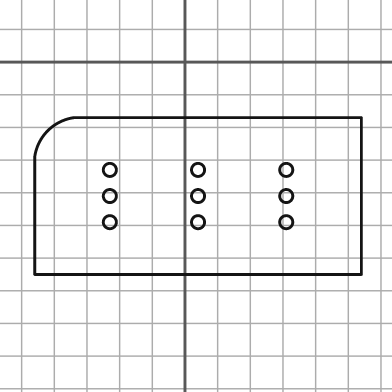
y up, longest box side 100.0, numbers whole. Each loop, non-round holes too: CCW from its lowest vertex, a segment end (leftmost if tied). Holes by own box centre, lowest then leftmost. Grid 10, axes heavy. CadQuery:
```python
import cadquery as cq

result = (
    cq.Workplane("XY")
    .moveTo(-46.0, -65.0)
    .lineTo(54.0, -65.0)
    .lineTo(54.0, -17.0)
    .lineTo(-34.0, -17.0)
    .threePointArc((-42.0, -21.0), (-46.0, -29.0))
    .close()
    .moveTo(-23.0, -49.0)
    .circle(2.0)
    .moveTo(4.0, -49.0)
    .circle(2.0)
    .moveTo(31.0, -49.0)
    .circle(2.0)
    .moveTo(-23.0, -41.0)
    .circle(2.0)
    .moveTo(4.0, -41.0)
    .circle(2.0)
    .moveTo(31.0, -41.0)
    .circle(2.0)
    .moveTo(-23.0, -33.0)
    .circle(2.0)
    .moveTo(4.0, -33.0)
    .circle(2.0)
    .moveTo(31.0, -33.0)
    .circle(2.0)
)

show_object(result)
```